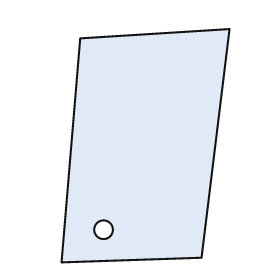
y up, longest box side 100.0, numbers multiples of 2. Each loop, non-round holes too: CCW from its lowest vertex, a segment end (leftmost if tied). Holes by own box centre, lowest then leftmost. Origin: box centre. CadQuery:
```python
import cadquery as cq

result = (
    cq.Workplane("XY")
    .moveTo(-36.0, -50.0)
    .lineTo(24.0, -48.0)
    .lineTo(36.0, 50.0)
    .lineTo(-28.0, 46.0)
    .close()
    .moveTo(-18.0, -36.0)
    .circle(4.0)
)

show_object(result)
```